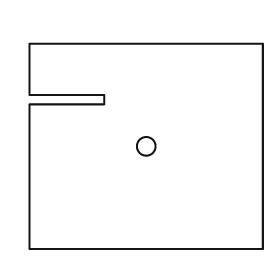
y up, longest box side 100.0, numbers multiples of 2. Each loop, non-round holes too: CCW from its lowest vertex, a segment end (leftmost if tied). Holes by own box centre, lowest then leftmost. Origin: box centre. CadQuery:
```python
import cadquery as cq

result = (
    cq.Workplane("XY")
    .moveTo(-50.0, -44.0)
    .lineTo(50.0, -44.0)
    .lineTo(50.0, 44.0)
    .lineTo(-50.0, 44.0)
    .lineTo(-50.0, 22.0)
    .lineTo(-18.0, 22.0)
    .lineTo(-18.0, 18.0)
    .lineTo(-50.0, 18.0)
    .close()
    .moveTo(0.0, 0.0)
    .circle(4.0)
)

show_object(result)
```